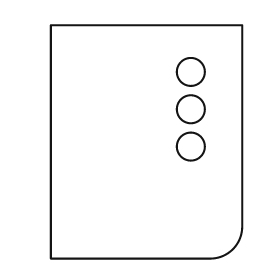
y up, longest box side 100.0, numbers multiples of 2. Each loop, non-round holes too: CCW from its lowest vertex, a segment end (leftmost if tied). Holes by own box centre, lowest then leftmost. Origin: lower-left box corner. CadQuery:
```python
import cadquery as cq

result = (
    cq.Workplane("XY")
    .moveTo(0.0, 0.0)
    .lineTo(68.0, 0.0)
    .threePointArc((78.0, 4.0), (82.0, 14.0))
    .lineTo(82.0, 100.0)
    .lineTo(0.0, 100.0)
    .close()
    .moveTo(60.0, 48.0)
    .circle(6.0)
    .moveTo(60.0, 64.0)
    .circle(6.0)
    .moveTo(60.0, 80.0)
    .circle(6.0)
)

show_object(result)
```